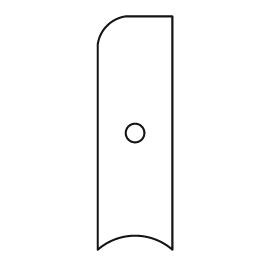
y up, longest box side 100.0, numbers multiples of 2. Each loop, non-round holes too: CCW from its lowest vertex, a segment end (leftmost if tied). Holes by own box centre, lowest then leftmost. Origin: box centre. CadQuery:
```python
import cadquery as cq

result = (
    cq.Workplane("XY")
    .moveTo(-16.0, -50.0)
    .threePointArc((0.0, -44.0), (16.0, -50.0))
    .lineTo(16.0, 50.0)
    .lineTo(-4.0, 50.0)
    .threePointArc((-12.0, 46.0), (-16.0, 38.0))
    .close()
    .moveTo(0.0, 0.0)
    .circle(4.0)
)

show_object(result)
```